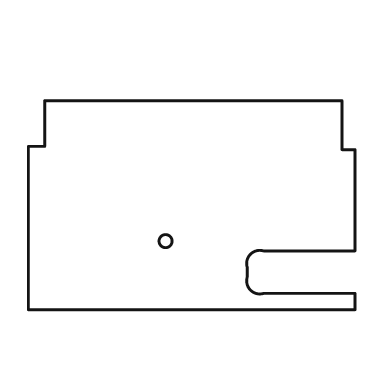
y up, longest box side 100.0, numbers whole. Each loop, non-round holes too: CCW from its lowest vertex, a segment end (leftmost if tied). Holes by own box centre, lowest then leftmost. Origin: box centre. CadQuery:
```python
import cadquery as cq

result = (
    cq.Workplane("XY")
    .moveTo(-50.0, -32.0)
    .lineTo(50.0, -32.0)
    .lineTo(50.0, -27.0)
    .lineTo(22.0, -27.0)
    .threePointArc((18.0, -26.0), (17.0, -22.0))
    .lineTo(17.0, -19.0)
    .threePointArc((18.0, -15.0), (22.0, -14.0))
    .lineTo(50.0, -14.0)
    .lineTo(50.0, 17.0)
    .lineTo(46.0, 17.0)
    .lineTo(46.0, 32.0)
    .lineTo(-45.0, 32.0)
    .lineTo(-45.0, 18.0)
    .lineTo(-50.0, 18.0)
    .close()
    .moveTo(-8.0, -11.0)
    .circle(2.0)
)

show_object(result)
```